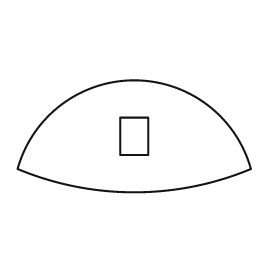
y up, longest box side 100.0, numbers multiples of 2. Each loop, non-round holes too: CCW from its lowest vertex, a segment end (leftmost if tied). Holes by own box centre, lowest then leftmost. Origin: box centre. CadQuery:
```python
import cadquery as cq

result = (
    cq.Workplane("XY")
    .moveTo(-50.0, -14.0)
    .threePointArc((0.0, -24.0), (50.0, -14.0))
    .threePointArc((0.0, 24.0), (-50.0, -14.0))
    .close()
    .moveTo(-6.0, -8.0)
    .lineTo(6.0, -8.0)
    .lineTo(6.0, 8.0)
    .lineTo(-6.0, 8.0)
    .close()
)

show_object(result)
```